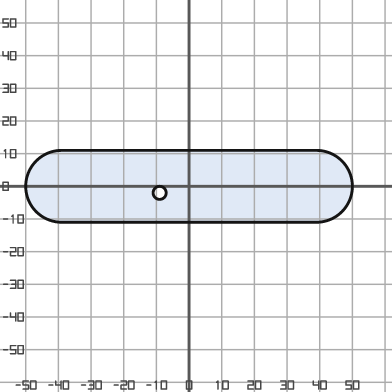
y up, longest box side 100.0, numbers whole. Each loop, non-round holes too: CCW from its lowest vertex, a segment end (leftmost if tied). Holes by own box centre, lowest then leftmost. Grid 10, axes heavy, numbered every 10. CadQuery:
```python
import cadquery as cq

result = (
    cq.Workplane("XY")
    .moveTo(-39.0, -11.0)
    .lineTo(39.0, -11.0)
    .threePointArc((50.0, 0.0), (39.0, 11.0))
    .lineTo(-39.0, 11.0)
    .threePointArc((-50.0, 0.0), (-39.0, -11.0))
    .close()
    .moveTo(-9.0, -2.0)
    .circle(2.0)
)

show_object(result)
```